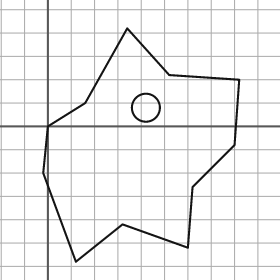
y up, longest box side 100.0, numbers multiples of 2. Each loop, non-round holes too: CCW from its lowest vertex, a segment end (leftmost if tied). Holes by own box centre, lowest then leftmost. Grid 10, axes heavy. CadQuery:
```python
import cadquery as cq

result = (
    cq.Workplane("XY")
    .moveTo(12.0, -58.0)
    .lineTo(32.0, -42.0)
    .lineTo(60.0, -52.0)
    .lineTo(62.0, -26.0)
    .lineTo(80.0, -8.0)
    .lineTo(82.0, 20.0)
    .lineTo(52.0, 22.0)
    .lineTo(34.0, 42.0)
    .lineTo(16.0, 10.0)
    .lineTo(0.0, 0.0)
    .lineTo(-2.0, -20.0)
    .close()
    .moveTo(42.0, 8.0)
    .circle(6.0)
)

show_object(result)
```